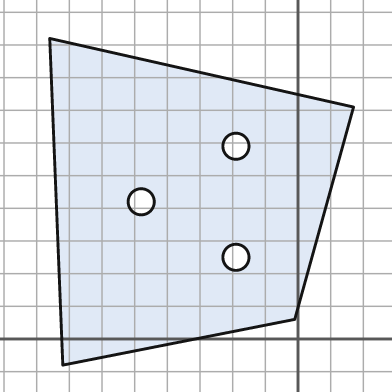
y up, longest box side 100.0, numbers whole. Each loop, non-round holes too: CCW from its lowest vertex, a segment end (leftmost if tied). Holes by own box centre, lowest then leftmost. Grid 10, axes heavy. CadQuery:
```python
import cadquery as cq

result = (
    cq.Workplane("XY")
    .moveTo(-72.0, -8.0)
    .lineTo(-1.0, 6.0)
    .lineTo(17.0, 71.0)
    .lineTo(-76.0, 92.0)
    .close()
    .moveTo(-19.0, 25.0)
    .circle(4.0)
    .moveTo(-48.0, 42.0)
    .circle(4.0)
    .moveTo(-19.0, 59.0)
    .circle(4.0)
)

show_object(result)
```